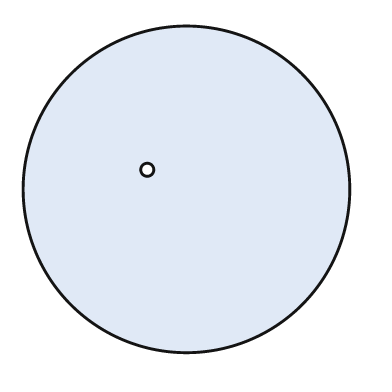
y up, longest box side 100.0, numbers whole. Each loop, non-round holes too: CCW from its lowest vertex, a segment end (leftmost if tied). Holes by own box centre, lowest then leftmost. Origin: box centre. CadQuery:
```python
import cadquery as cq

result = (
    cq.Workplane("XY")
    .moveTo(0.0, 0.0)
    .circle(50.0)
    .moveTo(-12.0, 6.0)
    .circle(2.0)
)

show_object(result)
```